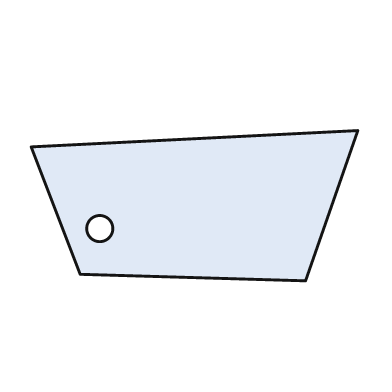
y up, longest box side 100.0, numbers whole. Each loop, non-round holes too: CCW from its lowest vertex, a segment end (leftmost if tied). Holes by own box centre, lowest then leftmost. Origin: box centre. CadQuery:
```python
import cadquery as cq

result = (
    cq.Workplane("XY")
    .moveTo(34.0, -23.0)
    .lineTo(50.0, 23.0)
    .lineTo(-50.0, 18.0)
    .lineTo(-35.0, -21.0)
    .close()
    .moveTo(-29.0, -7.0)
    .circle(4.0)
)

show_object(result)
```